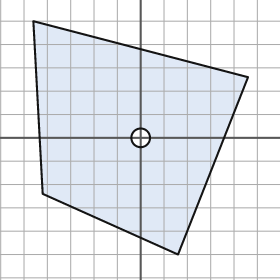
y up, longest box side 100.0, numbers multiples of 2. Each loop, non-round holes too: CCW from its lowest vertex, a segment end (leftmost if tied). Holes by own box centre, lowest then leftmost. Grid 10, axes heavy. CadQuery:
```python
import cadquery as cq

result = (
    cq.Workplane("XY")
    .moveTo(16.0, -50.0)
    .lineTo(46.0, 26.0)
    .lineTo(-46.0, 50.0)
    .lineTo(-42.0, -24.0)
    .close()
    .moveTo(0.0, 0.0)
    .circle(4.0)
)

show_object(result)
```